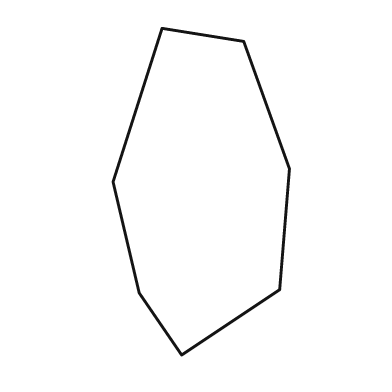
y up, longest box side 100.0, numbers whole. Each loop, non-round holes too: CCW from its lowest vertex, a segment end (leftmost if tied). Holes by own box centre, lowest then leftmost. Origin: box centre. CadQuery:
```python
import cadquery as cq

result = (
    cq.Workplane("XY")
    .moveTo(-6.0, -50.0)
    .lineTo(24.0, -30.0)
    .lineTo(27.0, 7.0)
    .lineTo(13.0, 46.0)
    .lineTo(-12.0, 50.0)
    .lineTo(-27.0, 3.0)
    .lineTo(-19.0, -31.0)
    .close()
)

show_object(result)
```